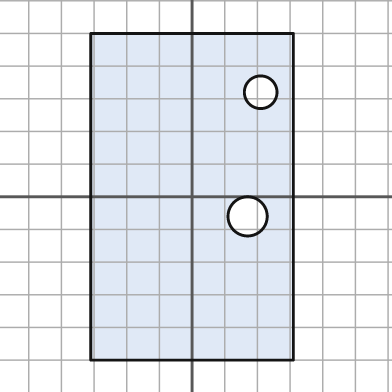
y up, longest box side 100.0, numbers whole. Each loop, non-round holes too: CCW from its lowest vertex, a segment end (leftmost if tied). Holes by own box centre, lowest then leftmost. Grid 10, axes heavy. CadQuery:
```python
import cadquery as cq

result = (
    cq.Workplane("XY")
    .moveTo(-31.0, -50.0)
    .lineTo(31.0, -50.0)
    .lineTo(31.0, 50.0)
    .lineTo(-31.0, 50.0)
    .close()
    .moveTo(17.0, -6.0)
    .circle(6.0)
    .moveTo(21.0, 32.0)
    .circle(5.0)
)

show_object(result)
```